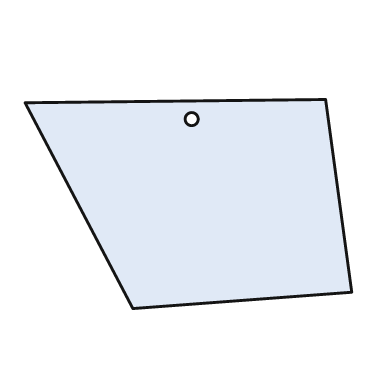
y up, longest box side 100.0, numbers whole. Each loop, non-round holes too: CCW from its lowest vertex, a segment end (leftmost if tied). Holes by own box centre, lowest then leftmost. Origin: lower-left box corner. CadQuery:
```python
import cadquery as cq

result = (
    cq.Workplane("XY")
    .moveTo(33.0, 0.0)
    .lineTo(100.0, 5.0)
    .lineTo(92.0, 64.0)
    .lineTo(0.0, 63.0)
    .close()
    .moveTo(51.0, 58.0)
    .circle(2.0)
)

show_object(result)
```